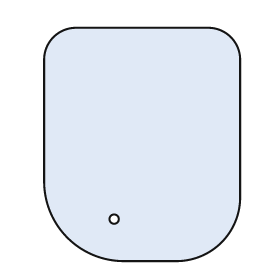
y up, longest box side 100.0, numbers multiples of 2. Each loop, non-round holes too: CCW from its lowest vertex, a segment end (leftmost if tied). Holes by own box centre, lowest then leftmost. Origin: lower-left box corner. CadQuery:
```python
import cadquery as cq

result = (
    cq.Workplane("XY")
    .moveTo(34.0, 0.0)
    .lineTo(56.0, 0.0)
    .threePointArc((76.0, 8.0), (84.0, 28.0))
    .lineTo(84.0, 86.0)
    .threePointArc((80.0, 96.0), (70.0, 100.0))
    .lineTo(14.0, 100.0)
    .threePointArc((4.0, 96.0), (0.0, 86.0))
    .lineTo(0.0, 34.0)
    .threePointArc((10.0, 10.0), (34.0, 0.0))
    .close()
    .moveTo(30.0, 18.0)
    .circle(2.0)
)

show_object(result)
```